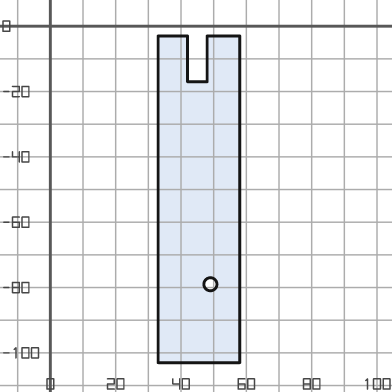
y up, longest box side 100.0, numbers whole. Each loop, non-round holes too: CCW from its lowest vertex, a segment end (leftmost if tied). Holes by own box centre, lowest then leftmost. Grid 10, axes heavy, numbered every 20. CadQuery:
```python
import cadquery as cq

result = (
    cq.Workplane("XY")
    .moveTo(33.0, -103.0)
    .lineTo(58.0, -103.0)
    .lineTo(58.0, -3.0)
    .lineTo(48.0, -3.0)
    .lineTo(48.0, -17.0)
    .lineTo(42.0, -17.0)
    .lineTo(42.0, -3.0)
    .lineTo(33.0, -3.0)
    .close()
    .moveTo(49.0, -79.0)
    .circle(2.0)
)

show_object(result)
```